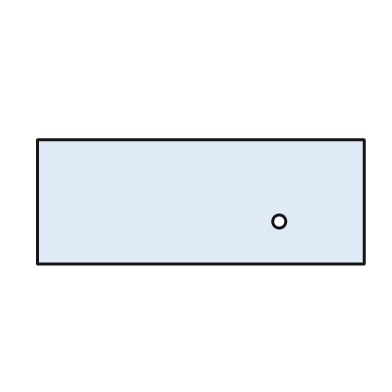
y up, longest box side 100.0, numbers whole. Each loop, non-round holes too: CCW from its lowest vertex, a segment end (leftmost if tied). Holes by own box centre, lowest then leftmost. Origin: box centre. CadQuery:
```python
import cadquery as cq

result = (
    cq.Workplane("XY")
    .moveTo(-50.0, -19.0)
    .lineTo(50.0, -19.0)
    .lineTo(50.0, 19.0)
    .lineTo(-50.0, 19.0)
    .close()
    .moveTo(24.0, -6.0)
    .circle(2.0)
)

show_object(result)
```